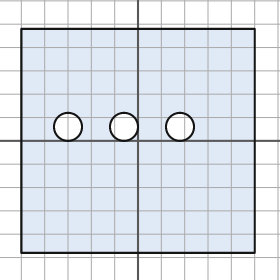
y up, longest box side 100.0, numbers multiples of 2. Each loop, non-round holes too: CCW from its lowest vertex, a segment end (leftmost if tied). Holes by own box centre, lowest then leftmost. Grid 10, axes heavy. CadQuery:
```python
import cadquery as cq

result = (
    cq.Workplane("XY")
    .moveTo(-50.0, -48.0)
    .lineTo(50.0, -48.0)
    .lineTo(50.0, 48.0)
    .lineTo(-50.0, 48.0)
    .close()
    .moveTo(-30.0, 6.0)
    .circle(6.0)
    .moveTo(-6.0, 6.0)
    .circle(6.0)
    .moveTo(18.0, 6.0)
    .circle(6.0)
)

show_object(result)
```